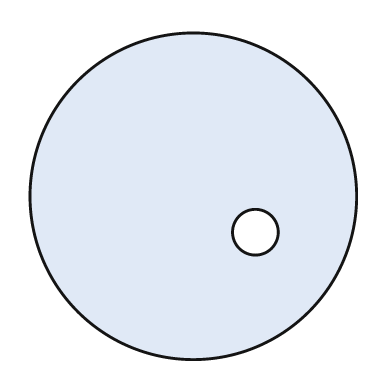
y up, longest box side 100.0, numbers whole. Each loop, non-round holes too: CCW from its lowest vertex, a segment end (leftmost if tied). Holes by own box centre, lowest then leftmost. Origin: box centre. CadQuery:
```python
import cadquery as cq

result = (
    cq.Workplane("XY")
    .moveTo(0.0, 0.0)
    .circle(50.0)
    .moveTo(19.0, -11.0)
    .circle(7.0)
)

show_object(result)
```